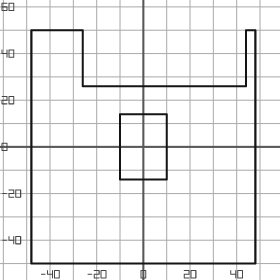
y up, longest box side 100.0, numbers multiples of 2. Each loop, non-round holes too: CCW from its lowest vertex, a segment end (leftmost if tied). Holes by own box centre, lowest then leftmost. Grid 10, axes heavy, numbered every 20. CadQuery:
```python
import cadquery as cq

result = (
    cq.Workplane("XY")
    .moveTo(-48.0, -50.0)
    .lineTo(48.0, -50.0)
    .lineTo(48.0, 50.0)
    .lineTo(44.0, 50.0)
    .lineTo(44.0, 26.0)
    .lineTo(-26.0, 26.0)
    .lineTo(-26.0, 50.0)
    .lineTo(-48.0, 50.0)
    .close()
    .moveTo(-10.0, -14.0)
    .lineTo(10.0, -14.0)
    .lineTo(10.0, 14.0)
    .lineTo(-10.0, 14.0)
    .close()
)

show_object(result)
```